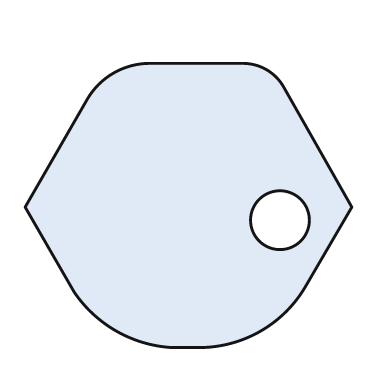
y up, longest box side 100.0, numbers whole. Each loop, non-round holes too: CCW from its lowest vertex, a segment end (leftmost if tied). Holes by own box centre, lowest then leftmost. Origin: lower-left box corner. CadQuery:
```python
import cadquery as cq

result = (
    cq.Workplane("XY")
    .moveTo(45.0, 0.0)
    .lineTo(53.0, 0.0)
    .threePointArc((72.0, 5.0), (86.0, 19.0))
    .lineTo(100.0, 43.0)
    .lineTo(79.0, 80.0)
    .threePointArc((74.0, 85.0), (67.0, 87.0))
    .lineTo(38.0, 87.0)
    .threePointArc((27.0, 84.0), (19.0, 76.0))
    .lineTo(0.0, 43.0)
    .lineTo(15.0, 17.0)
    .threePointArc((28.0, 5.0), (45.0, 0.0))
    .close()
    .moveTo(78.0, 39.0)
    .circle(9.0)
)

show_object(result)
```